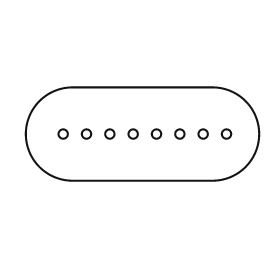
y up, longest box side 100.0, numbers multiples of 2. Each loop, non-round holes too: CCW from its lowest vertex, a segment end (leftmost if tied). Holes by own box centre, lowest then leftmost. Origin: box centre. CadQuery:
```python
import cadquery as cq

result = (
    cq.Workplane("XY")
    .moveTo(-30.0, -20.0)
    .lineTo(30.0, -20.0)
    .threePointArc((50.0, 0.0), (30.0, 20.0))
    .lineTo(-30.0, 20.0)
    .threePointArc((-50.0, 0.0), (-30.0, -20.0))
    .close()
    .moveTo(-34.0, 0.0)
    .circle(2.0)
    .moveTo(-24.0, 0.0)
    .circle(2.0)
    .moveTo(-14.0, 0.0)
    .circle(2.0)
    .moveTo(-4.0, 0.0)
    .circle(2.0)
    .moveTo(6.0, 0.0)
    .circle(2.0)
    .moveTo(16.0, 0.0)
    .circle(2.0)
    .moveTo(26.0, 0.0)
    .circle(2.0)
    .moveTo(36.0, 0.0)
    .circle(2.0)
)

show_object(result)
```